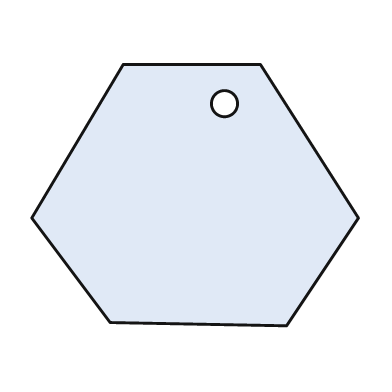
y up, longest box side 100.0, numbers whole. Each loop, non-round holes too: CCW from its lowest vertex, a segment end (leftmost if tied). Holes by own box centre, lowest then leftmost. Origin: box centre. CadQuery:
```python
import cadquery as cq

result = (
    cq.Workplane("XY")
    .moveTo(28.0, -40.0)
    .lineTo(50.0, -7.0)
    .lineTo(20.0, 40.0)
    .lineTo(-22.0, 40.0)
    .lineTo(-50.0, -7.0)
    .lineTo(-26.0, -39.0)
    .close()
    .moveTo(9.0, 28.0)
    .circle(4.0)
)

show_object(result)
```